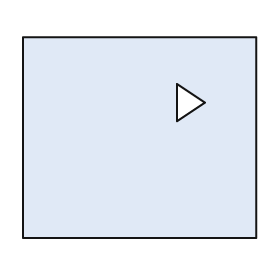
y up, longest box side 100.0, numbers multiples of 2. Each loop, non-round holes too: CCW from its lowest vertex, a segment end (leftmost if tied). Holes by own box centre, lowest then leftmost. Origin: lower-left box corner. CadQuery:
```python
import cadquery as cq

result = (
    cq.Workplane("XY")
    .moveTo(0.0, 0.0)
    .lineTo(100.0, 0.0)
    .lineTo(100.0, 86.0)
    .lineTo(0.0, 86.0)
    .close()
    .moveTo(66.0, 50.0)
    .lineTo(78.0, 58.0)
    .lineTo(66.0, 66.0)
    .close()
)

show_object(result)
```